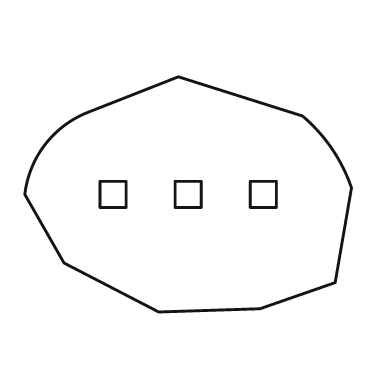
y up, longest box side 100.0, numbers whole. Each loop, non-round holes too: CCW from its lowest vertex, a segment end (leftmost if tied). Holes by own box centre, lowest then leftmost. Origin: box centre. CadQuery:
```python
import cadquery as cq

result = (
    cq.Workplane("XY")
    .moveTo(-9.0, -36.0)
    .lineTo(22.0, -35.0)
    .lineTo(45.0, -27.0)
    .lineTo(50.0, 2.0)
    .threePointArc((44.0, 14.0), (35.0, 24.0))
    .lineTo(-3.0, 36.0)
    .lineTo(-31.0, 25.0)
    .threePointArc((-44.0, 15.0), (-50.0, 0.0))
    .lineTo(-38.0, -21.0)
    .close()
    .moveTo(-27.0, -4.0)
    .lineTo(-19.0, -4.0)
    .lineTo(-19.0, 4.0)
    .lineTo(-27.0, 4.0)
    .close()
    .moveTo(-4.0, -4.0)
    .lineTo(4.0, -4.0)
    .lineTo(4.0, 4.0)
    .lineTo(-4.0, 4.0)
    .close()
    .moveTo(19.0, -4.0)
    .lineTo(27.0, -4.0)
    .lineTo(27.0, 4.0)
    .lineTo(19.0, 4.0)
    .close()
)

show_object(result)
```